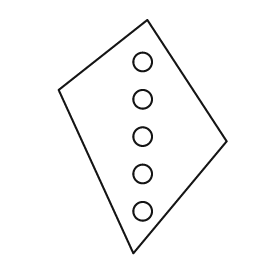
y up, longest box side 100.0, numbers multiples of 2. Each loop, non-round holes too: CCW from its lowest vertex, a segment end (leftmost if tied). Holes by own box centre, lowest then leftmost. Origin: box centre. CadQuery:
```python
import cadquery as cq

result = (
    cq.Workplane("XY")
    .moveTo(-4.0, -50.0)
    .lineTo(36.0, -2.0)
    .lineTo(2.0, 50.0)
    .lineTo(-36.0, 20.0)
    .close()
    .moveTo(0.0, -32.0)
    .circle(4.0)
    .moveTo(0.0, -16.0)
    .circle(4.0)
    .moveTo(0.0, 0.0)
    .circle(4.0)
    .moveTo(0.0, 16.0)
    .circle(4.0)
    .moveTo(0.0, 32.0)
    .circle(4.0)
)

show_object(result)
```